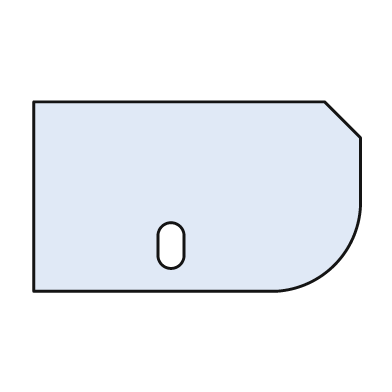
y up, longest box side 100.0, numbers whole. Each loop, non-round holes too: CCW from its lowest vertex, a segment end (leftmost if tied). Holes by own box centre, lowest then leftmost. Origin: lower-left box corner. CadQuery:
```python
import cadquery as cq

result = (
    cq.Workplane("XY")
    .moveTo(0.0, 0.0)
    .lineTo(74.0, 0.0)
    .threePointArc((92.0, 8.0), (100.0, 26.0))
    .lineTo(100.0, 47.0)
    .lineTo(89.0, 58.0)
    .lineTo(0.0, 58.0)
    .close()
    .moveTo(38.0, 11.0)
    .threePointArc((42.0, 7.0), (46.0, 11.0))
    .lineTo(46.0, 17.0)
    .threePointArc((42.0, 21.0), (38.0, 17.0))
    .close()
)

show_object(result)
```